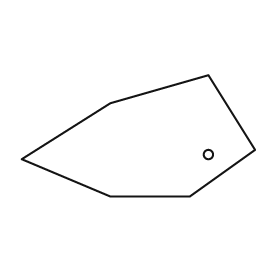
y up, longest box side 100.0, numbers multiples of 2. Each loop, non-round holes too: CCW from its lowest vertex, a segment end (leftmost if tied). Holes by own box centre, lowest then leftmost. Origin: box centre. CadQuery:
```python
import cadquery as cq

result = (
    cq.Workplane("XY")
    .moveTo(-12.0, -26.0)
    .lineTo(22.0, -26.0)
    .lineTo(50.0, -6.0)
    .lineTo(30.0, 26.0)
    .lineTo(-12.0, 14.0)
    .lineTo(-50.0, -10.0)
    .close()
    .moveTo(30.0, -8.0)
    .circle(2.0)
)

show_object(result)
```